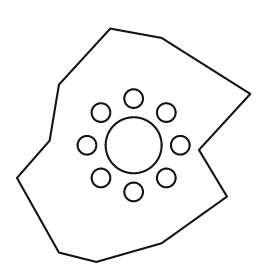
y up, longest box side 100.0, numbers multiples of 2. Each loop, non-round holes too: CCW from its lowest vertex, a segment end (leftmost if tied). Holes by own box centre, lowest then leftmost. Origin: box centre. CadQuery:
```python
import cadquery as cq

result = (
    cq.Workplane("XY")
    .moveTo(-16.0, -50.0)
    .lineTo(12.0, -42.0)
    .lineTo(40.0, -22.0)
    .lineTo(28.0, -2.0)
    .lineTo(50.0, 22.0)
    .lineTo(12.0, 46.0)
    .lineTo(-10.0, 50.0)
    .lineTo(-32.0, 26.0)
    .lineTo(-36.0, 2.0)
    .lineTo(-50.0, -14.0)
    .lineTo(-32.0, -46.0)
    .close()
    .moveTo(0.0, -20.0)
    .circle(4.0)
    .moveTo(-14.0, -14.0)
    .circle(4.0)
    .moveTo(14.0, -14.0)
    .circle(4.0)
    .moveTo(-20.0, 0.0)
    .circle(4.0)
    .moveTo(0.0, 0.0)
    .circle(12.0)
    .moveTo(20.0, 0.0)
    .circle(4.0)
    .moveTo(-14.0, 14.0)
    .circle(4.0)
    .moveTo(14.0, 14.0)
    .circle(4.0)
    .moveTo(0.0, 20.0)
    .circle(4.0)
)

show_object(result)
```